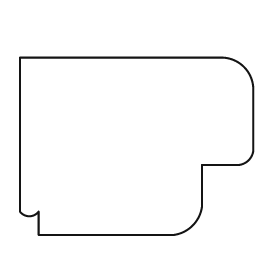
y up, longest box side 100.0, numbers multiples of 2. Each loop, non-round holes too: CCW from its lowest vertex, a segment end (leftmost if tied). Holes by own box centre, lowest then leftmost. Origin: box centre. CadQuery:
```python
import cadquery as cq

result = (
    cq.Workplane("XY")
    .moveTo(-42.0, -38.0)
    .lineTo(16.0, -38.0)
    .threePointArc((24.0, -34.0), (28.0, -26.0))
    .lineTo(28.0, -8.0)
    .lineTo(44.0, -8.0)
    .threePointArc((48.0, -6.0), (50.0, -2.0))
    .lineTo(50.0, 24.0)
    .threePointArc((46.0, 34.0), (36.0, 38.0))
    .lineTo(-50.0, 38.0)
    .lineTo(-50.0, -28.0)
    .threePointArc((-46.0, -30.0), (-42.0, -28.0))
    .close()
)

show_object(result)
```